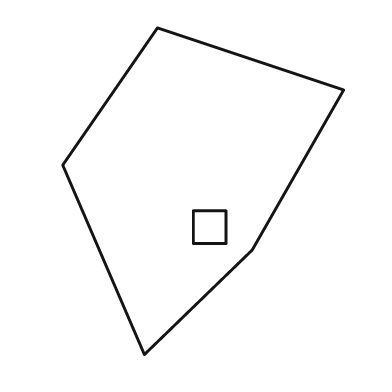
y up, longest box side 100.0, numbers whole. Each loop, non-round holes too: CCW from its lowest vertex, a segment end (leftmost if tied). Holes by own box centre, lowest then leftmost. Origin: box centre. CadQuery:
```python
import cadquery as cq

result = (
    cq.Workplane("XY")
    .moveTo(-18.0, -50.0)
    .lineTo(15.0, -18.0)
    .lineTo(43.0, 31.0)
    .lineTo(-14.0, 50.0)
    .lineTo(-43.0, 8.0)
    .close()
    .moveTo(-3.0, -16.0)
    .lineTo(7.0, -16.0)
    .lineTo(7.0, -6.0)
    .lineTo(-3.0, -6.0)
    .close()
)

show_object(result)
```